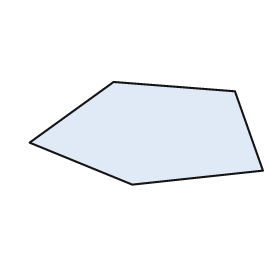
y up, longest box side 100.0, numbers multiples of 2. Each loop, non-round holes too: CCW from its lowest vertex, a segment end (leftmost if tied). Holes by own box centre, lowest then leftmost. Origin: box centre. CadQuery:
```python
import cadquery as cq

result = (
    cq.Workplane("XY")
    .moveTo(-6.0, -22.0)
    .lineTo(50.0, -16.0)
    .lineTo(38.0, 18.0)
    .lineTo(-14.0, 22.0)
    .lineTo(-50.0, -4.0)
    .close()
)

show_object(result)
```